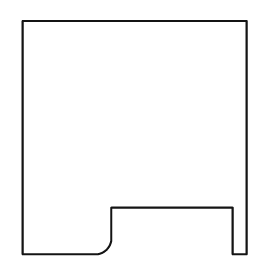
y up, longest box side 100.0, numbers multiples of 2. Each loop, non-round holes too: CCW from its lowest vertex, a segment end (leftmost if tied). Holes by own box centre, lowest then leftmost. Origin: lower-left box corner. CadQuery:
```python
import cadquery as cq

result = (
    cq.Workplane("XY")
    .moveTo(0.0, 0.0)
    .lineTo(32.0, 0.0)
    .threePointArc((36.0, 2.0), (38.0, 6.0))
    .lineTo(38.0, 20.0)
    .lineTo(90.0, 20.0)
    .lineTo(90.0, 0.0)
    .lineTo(96.0, 0.0)
    .lineTo(96.0, 100.0)
    .lineTo(0.0, 100.0)
    .close()
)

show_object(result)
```